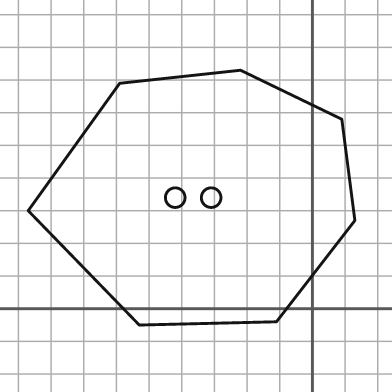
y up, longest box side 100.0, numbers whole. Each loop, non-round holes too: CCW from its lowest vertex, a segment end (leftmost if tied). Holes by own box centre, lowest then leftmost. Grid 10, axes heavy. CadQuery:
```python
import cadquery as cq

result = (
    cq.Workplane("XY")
    .moveTo(-53.0, -5.0)
    .lineTo(-11.0, -4.0)
    .lineTo(13.0, 27.0)
    .lineTo(9.0, 58.0)
    .lineTo(-22.0, 73.0)
    .lineTo(-59.0, 69.0)
    .lineTo(-87.0, 30.0)
    .close()
    .moveTo(-42.0, 34.0)
    .circle(3.0)
    .moveTo(-31.0, 34.0)
    .circle(3.0)
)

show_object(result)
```